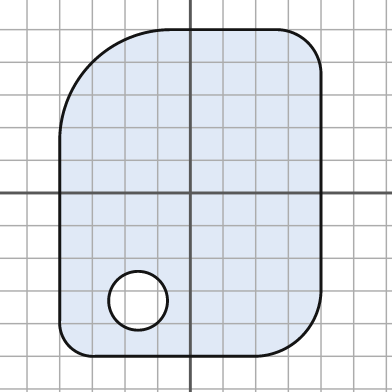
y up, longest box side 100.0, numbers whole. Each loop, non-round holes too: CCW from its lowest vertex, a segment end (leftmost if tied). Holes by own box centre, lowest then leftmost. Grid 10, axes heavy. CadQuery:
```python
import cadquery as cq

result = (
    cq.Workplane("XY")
    .moveTo(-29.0, -50.0)
    .lineTo(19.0, -50.0)
    .threePointArc((34.0, -44.0), (40.0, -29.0))
    .lineTo(40.0, 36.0)
    .threePointArc((36.0, 46.0), (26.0, 50.0))
    .lineTo(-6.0, 50.0)
    .threePointArc((-30.0, 40.0), (-40.0, 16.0))
    .lineTo(-40.0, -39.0)
    .threePointArc((-37.0, -47.0), (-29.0, -50.0))
    .close()
    .moveTo(-16.0, -33.0)
    .circle(9.0)
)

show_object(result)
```